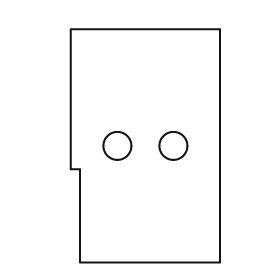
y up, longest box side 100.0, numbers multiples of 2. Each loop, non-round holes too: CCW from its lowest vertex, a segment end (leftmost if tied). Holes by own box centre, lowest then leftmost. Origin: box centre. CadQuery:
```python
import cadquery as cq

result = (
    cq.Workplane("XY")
    .moveTo(-28.0, -50.0)
    .lineTo(32.0, -50.0)
    .lineTo(32.0, 50.0)
    .lineTo(-32.0, 50.0)
    .lineTo(-32.0, -10.0)
    .lineTo(-28.0, -10.0)
    .close()
    .moveTo(-12.0, 0.0)
    .circle(6.0)
    .moveTo(12.0, 0.0)
    .circle(6.0)
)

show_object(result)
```